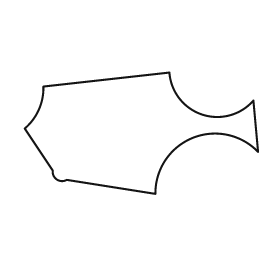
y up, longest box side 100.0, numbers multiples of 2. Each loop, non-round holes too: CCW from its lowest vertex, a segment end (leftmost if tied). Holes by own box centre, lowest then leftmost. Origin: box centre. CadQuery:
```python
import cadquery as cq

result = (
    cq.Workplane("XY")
    .moveTo(6.0, -26.0)
    .threePointArc((22.0, -2.0), (50.0, -8.0))
    .lineTo(48.0, 14.0)
    .threePointArc((26.0, 8.0), (12.0, 26.0))
    .lineTo(-42.0, 20.0)
    .threePointArc((-44.0, 10.0), (-50.0, 2.0))
    .lineTo(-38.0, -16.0)
    .threePointArc((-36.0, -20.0), (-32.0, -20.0))
    .close()
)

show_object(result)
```